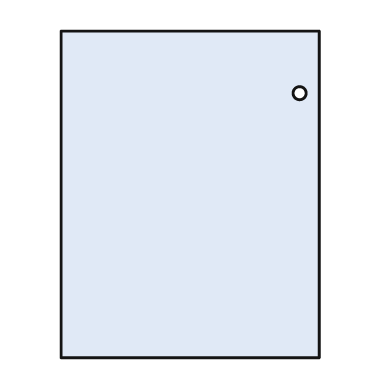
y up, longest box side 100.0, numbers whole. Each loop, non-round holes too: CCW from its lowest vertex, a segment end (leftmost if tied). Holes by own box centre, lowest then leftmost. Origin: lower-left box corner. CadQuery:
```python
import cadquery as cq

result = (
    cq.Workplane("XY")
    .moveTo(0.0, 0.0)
    .lineTo(79.0, 0.0)
    .lineTo(79.0, 100.0)
    .lineTo(0.0, 100.0)
    .close()
    .moveTo(73.0, 81.0)
    .circle(2.0)
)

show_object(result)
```